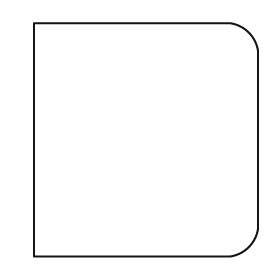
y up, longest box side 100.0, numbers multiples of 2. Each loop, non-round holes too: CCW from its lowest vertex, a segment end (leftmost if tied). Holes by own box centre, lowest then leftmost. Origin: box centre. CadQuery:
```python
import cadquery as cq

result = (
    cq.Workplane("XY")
    .moveTo(-48.0, -50.0)
    .lineTo(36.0, -50.0)
    .threePointArc((44.0, -46.0), (48.0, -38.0))
    .lineTo(48.0, 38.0)
    .threePointArc((44.0, 46.0), (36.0, 50.0))
    .lineTo(-48.0, 50.0)
    .close()
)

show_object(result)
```